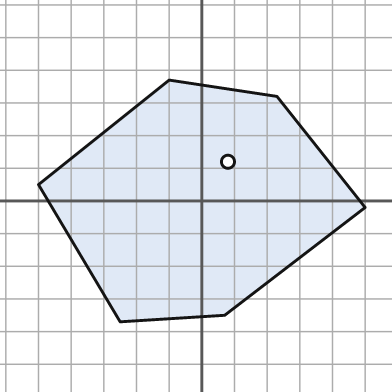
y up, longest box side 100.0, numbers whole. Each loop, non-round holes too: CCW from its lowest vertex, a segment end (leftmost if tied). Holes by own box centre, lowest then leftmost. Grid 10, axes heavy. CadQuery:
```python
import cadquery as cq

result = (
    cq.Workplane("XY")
    .moveTo(-25.0, -37.0)
    .lineTo(7.0, -35.0)
    .lineTo(50.0, -2.0)
    .lineTo(23.0, 32.0)
    .lineTo(-10.0, 37.0)
    .lineTo(-50.0, 5.0)
    .close()
    .moveTo(8.0, 12.0)
    .circle(2.0)
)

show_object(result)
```